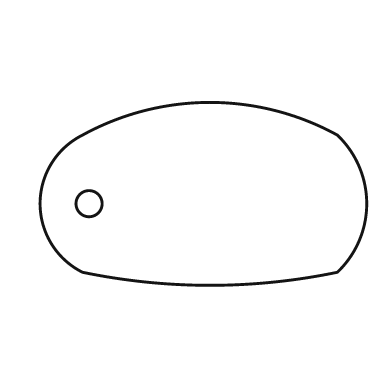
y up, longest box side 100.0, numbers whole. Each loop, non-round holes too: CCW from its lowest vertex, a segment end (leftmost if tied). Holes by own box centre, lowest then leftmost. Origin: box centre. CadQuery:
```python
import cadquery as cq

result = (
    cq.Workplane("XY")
    .moveTo(-37.0, -24.0)
    .threePointArc((2.0, -28.0), (41.0, -24.0))
    .threePointArc((50.0, -3.0), (41.0, 18.0))
    .threePointArc((2.0, 28.0), (-37.0, 18.0))
    .threePointArc((-50.0, -3.0), (-37.0, -24.0))
    .close()
    .moveTo(-35.0, -3.0)
    .circle(4.0)
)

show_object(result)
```